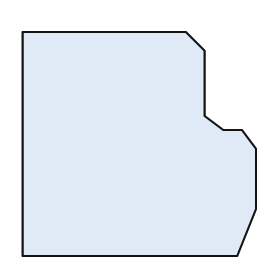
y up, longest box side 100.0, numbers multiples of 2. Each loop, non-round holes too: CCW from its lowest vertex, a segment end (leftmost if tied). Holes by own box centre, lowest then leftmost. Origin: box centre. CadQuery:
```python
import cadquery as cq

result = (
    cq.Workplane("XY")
    .moveTo(-50.0, -48.0)
    .lineTo(42.0, -48.0)
    .lineTo(50.0, -28.0)
    .lineTo(50.0, -2.0)
    .lineTo(44.0, 6.0)
    .lineTo(36.0, 6.0)
    .lineTo(28.0, 12.0)
    .lineTo(28.0, 40.0)
    .lineTo(20.0, 48.0)
    .lineTo(-50.0, 48.0)
    .close()
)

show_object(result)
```